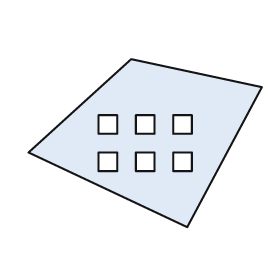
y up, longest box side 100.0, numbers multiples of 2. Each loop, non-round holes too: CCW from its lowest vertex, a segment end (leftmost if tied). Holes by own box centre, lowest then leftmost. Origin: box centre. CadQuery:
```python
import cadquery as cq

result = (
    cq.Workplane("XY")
    .moveTo(18.0, -36.0)
    .lineTo(50.0, 24.0)
    .lineTo(-6.0, 36.0)
    .lineTo(-50.0, -4.0)
    .close()
    .moveTo(-20.0, -12.0)
    .lineTo(-12.0, -12.0)
    .lineTo(-12.0, -4.0)
    .lineTo(-20.0, -4.0)
    .close()
    .moveTo(-4.0, -12.0)
    .lineTo(4.0, -12.0)
    .lineTo(4.0, -4.0)
    .lineTo(-4.0, -4.0)
    .close()
    .moveTo(12.0, -12.0)
    .lineTo(20.0, -12.0)
    .lineTo(20.0, -4.0)
    .lineTo(12.0, -4.0)
    .close()
    .moveTo(-20.0, 4.0)
    .lineTo(-12.0, 4.0)
    .lineTo(-12.0, 12.0)
    .lineTo(-20.0, 12.0)
    .close()
    .moveTo(-4.0, 4.0)
    .lineTo(4.0, 4.0)
    .lineTo(4.0, 12.0)
    .lineTo(-4.0, 12.0)
    .close()
    .moveTo(12.0, 4.0)
    .lineTo(20.0, 4.0)
    .lineTo(20.0, 12.0)
    .lineTo(12.0, 12.0)
    .close()
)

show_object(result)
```